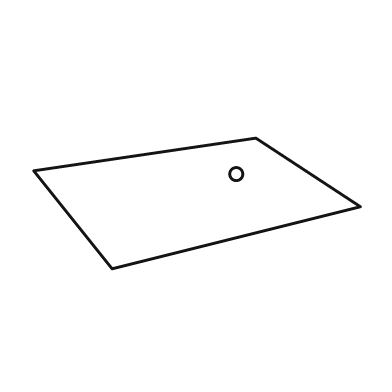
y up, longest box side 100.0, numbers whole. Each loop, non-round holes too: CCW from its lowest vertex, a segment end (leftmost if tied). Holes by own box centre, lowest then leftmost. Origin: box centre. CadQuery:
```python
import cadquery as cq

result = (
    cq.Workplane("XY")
    .moveTo(-26.0, -20.0)
    .lineTo(50.0, -1.0)
    .lineTo(18.0, 20.0)
    .lineTo(-50.0, 10.0)
    .close()
    .moveTo(12.0, 9.0)
    .circle(2.0)
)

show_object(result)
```